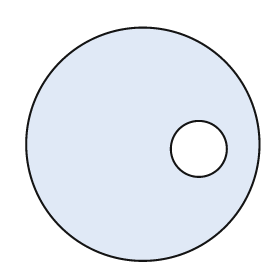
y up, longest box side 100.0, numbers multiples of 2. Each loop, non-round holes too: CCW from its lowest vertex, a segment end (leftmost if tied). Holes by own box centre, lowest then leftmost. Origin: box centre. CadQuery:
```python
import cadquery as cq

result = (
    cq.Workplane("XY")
    .moveTo(0.0, 0.0)
    .circle(50.0)
    .moveTo(24.0, -2.0)
    .circle(12.0)
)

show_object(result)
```